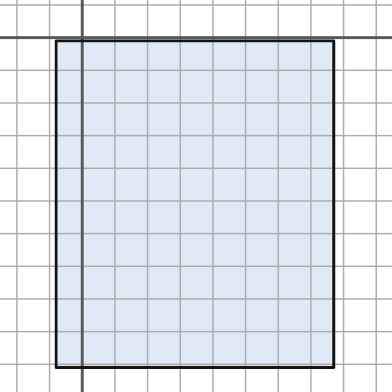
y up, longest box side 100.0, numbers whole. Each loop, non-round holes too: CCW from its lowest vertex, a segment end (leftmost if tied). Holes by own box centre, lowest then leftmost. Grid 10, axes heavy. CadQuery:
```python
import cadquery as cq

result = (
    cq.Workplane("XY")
    .moveTo(-8.0, -101.0)
    .lineTo(77.0, -101.0)
    .lineTo(77.0, -1.0)
    .lineTo(-8.0, -1.0)
    .close()
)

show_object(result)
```